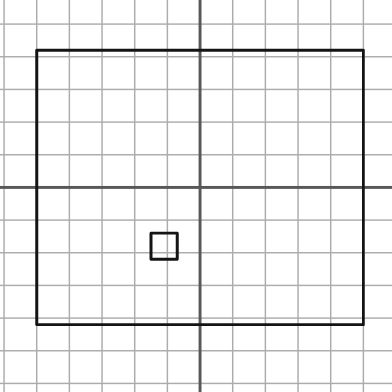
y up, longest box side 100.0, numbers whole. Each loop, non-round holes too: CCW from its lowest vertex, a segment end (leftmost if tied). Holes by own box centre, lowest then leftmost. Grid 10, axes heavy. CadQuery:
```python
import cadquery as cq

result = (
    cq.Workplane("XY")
    .moveTo(-50.0, -42.0)
    .lineTo(50.0, -42.0)
    .lineTo(50.0, 42.0)
    .lineTo(-50.0, 42.0)
    .close()
    .moveTo(-15.0, -22.0)
    .lineTo(-7.0, -22.0)
    .lineTo(-7.0, -14.0)
    .lineTo(-15.0, -14.0)
    .close()
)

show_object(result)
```